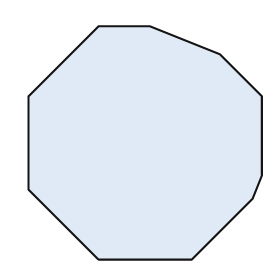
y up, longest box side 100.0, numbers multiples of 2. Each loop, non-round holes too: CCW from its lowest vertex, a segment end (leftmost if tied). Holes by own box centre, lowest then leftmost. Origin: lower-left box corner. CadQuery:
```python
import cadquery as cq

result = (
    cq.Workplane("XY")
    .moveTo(30.0, 0.0)
    .lineTo(70.0, 0.0)
    .lineTo(96.0, 26.0)
    .lineTo(100.0, 36.0)
    .lineTo(100.0, 70.0)
    .lineTo(82.0, 88.0)
    .lineTo(52.0, 100.0)
    .lineTo(30.0, 100.0)
    .lineTo(0.0, 70.0)
    .lineTo(0.0, 30.0)
    .close()
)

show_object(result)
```